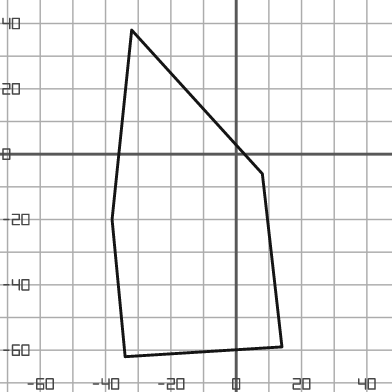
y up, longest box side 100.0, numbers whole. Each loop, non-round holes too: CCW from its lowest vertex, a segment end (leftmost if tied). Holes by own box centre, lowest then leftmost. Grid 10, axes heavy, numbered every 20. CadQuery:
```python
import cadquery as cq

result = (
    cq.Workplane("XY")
    .moveTo(-34.0, -62.0)
    .lineTo(14.0, -59.0)
    .lineTo(8.0, -6.0)
    .lineTo(-32.0, 38.0)
    .lineTo(-38.0, -20.0)
    .close()
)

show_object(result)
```